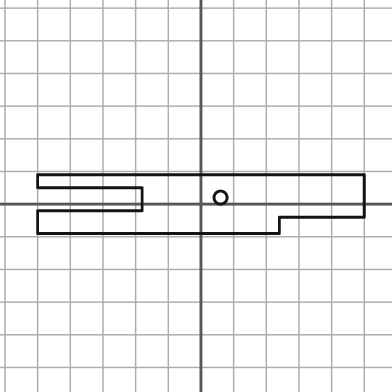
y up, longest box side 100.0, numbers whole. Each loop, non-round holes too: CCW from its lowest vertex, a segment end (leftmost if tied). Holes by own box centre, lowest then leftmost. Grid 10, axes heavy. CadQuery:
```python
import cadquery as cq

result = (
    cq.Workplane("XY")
    .moveTo(-50.0, -9.0)
    .lineTo(24.0, -9.0)
    .lineTo(24.0, -4.0)
    .lineTo(50.0, -4.0)
    .lineTo(50.0, 9.0)
    .lineTo(-50.0, 9.0)
    .lineTo(-50.0, 5.0)
    .lineTo(-18.0, 5.0)
    .lineTo(-18.0, -2.0)
    .lineTo(-50.0, -2.0)
    .close()
    .moveTo(6.0, 2.0)
    .circle(2.0)
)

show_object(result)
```